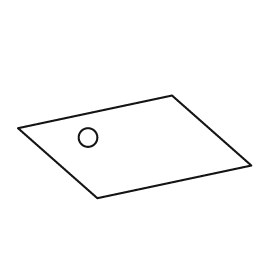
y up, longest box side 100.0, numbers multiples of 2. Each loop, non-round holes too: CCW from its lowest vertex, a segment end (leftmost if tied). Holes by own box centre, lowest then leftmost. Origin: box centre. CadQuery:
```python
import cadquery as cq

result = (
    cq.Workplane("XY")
    .moveTo(-16.0, -22.0)
    .lineTo(50.0, -8.0)
    .lineTo(16.0, 22.0)
    .lineTo(-50.0, 8.0)
    .close()
    .moveTo(-20.0, 4.0)
    .circle(4.0)
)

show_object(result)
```